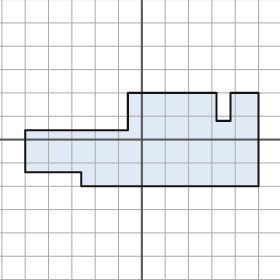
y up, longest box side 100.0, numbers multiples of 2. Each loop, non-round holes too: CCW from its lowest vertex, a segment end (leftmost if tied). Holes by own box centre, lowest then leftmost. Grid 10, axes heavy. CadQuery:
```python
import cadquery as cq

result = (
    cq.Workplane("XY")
    .moveTo(-26.0, -20.0)
    .lineTo(50.0, -20.0)
    .lineTo(50.0, 20.0)
    .lineTo(38.0, 20.0)
    .lineTo(38.0, 8.0)
    .lineTo(32.0, 8.0)
    .lineTo(32.0, 20.0)
    .lineTo(-6.0, 20.0)
    .lineTo(-6.0, 4.0)
    .lineTo(-50.0, 4.0)
    .lineTo(-50.0, -14.0)
    .lineTo(-26.0, -14.0)
    .close()
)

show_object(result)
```